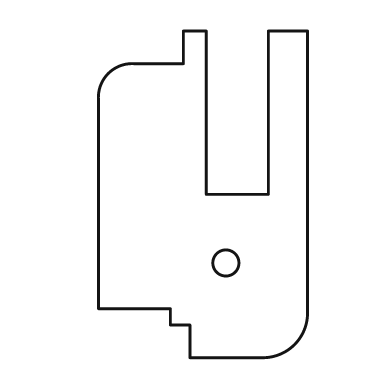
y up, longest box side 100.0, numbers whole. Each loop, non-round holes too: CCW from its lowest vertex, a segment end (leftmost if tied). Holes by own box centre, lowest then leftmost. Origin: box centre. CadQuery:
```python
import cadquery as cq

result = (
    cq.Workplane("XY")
    .moveTo(-4.0, -50.0)
    .lineTo(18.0, -50.0)
    .threePointArc((28.0, -46.0), (32.0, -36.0))
    .lineTo(32.0, 50.0)
    .lineTo(20.0, 50.0)
    .lineTo(20.0, 0.0)
    .lineTo(1.0, 0.0)
    .lineTo(1.0, 50.0)
    .lineTo(-6.0, 50.0)
    .lineTo(-6.0, 40.0)
    .lineTo(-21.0, 40.0)
    .threePointArc((-29.0, 37.0), (-32.0, 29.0))
    .lineTo(-32.0, -35.0)
    .lineTo(-10.0, -35.0)
    .lineTo(-10.0, -40.0)
    .lineTo(-4.0, -40.0)
    .close()
    .moveTo(7.0, -21.0)
    .circle(4.0)
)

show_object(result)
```